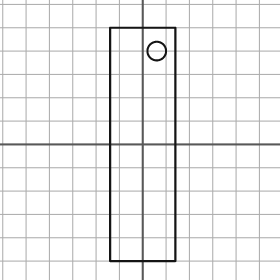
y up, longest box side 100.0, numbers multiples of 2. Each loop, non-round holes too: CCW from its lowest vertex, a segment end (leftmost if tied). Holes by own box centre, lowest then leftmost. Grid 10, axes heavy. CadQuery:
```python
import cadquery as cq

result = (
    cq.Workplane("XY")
    .moveTo(-14.0, -50.0)
    .lineTo(14.0, -50.0)
    .lineTo(14.0, 50.0)
    .lineTo(-14.0, 50.0)
    .close()
    .moveTo(6.0, 40.0)
    .circle(4.0)
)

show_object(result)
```